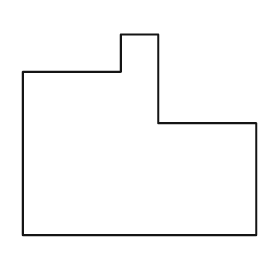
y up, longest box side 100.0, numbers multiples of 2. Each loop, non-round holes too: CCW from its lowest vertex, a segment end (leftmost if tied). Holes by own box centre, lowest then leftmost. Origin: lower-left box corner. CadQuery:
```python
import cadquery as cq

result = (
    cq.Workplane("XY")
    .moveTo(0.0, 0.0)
    .lineTo(100.0, 0.0)
    .lineTo(100.0, 48.0)
    .lineTo(58.0, 48.0)
    .lineTo(58.0, 86.0)
    .lineTo(42.0, 86.0)
    .lineTo(42.0, 70.0)
    .lineTo(0.0, 70.0)
    .close()
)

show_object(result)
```